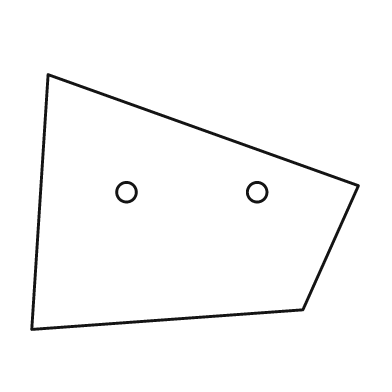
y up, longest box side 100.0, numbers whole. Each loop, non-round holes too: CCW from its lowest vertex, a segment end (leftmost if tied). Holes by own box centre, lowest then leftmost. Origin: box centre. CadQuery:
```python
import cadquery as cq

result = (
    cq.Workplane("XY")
    .moveTo(-50.0, -39.0)
    .lineTo(33.0, -33.0)
    .lineTo(50.0, 5.0)
    .lineTo(-45.0, 39.0)
    .close()
    .moveTo(-21.0, 3.0)
    .circle(3.0)
    .moveTo(19.0, 3.0)
    .circle(3.0)
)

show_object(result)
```